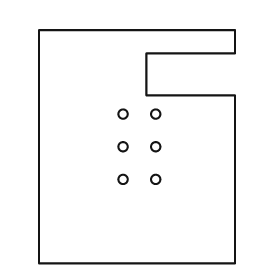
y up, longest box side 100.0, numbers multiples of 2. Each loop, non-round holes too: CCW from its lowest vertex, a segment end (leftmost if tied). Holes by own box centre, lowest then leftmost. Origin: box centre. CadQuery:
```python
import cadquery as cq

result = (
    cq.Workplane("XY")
    .moveTo(-42.0, -50.0)
    .lineTo(42.0, -50.0)
    .lineTo(42.0, 22.0)
    .lineTo(4.0, 22.0)
    .lineTo(4.0, 40.0)
    .lineTo(42.0, 40.0)
    .lineTo(42.0, 50.0)
    .lineTo(-42.0, 50.0)
    .close()
    .moveTo(-6.0, -14.0)
    .circle(2.0)
    .moveTo(8.0, -14.0)
    .circle(2.0)
    .moveTo(-6.0, 0.0)
    .circle(2.0)
    .moveTo(8.0, 0.0)
    .circle(2.0)
    .moveTo(-6.0, 14.0)
    .circle(2.0)
    .moveTo(8.0, 14.0)
    .circle(2.0)
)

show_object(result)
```